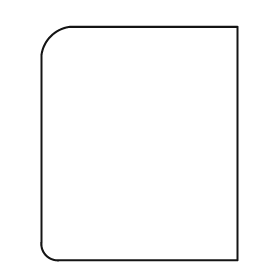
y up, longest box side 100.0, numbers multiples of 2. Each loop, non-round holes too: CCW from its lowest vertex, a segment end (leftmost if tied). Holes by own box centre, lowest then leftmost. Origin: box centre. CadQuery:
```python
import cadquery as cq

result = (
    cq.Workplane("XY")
    .moveTo(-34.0, -50.0)
    .lineTo(42.0, -50.0)
    .lineTo(42.0, 50.0)
    .lineTo(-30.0, 50.0)
    .threePointArc((-38.0, 46.0), (-42.0, 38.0))
    .lineTo(-42.0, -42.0)
    .threePointArc((-40.0, -48.0), (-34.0, -50.0))
    .close()
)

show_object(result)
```